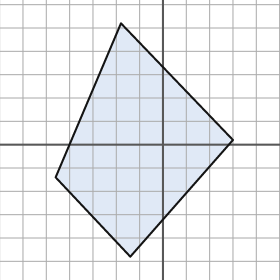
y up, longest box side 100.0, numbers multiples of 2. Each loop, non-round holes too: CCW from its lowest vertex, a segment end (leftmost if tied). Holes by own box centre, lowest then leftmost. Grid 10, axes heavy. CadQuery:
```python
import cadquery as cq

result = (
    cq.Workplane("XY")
    .moveTo(-14.0, -48.0)
    .lineTo(30.0, 2.0)
    .lineTo(-18.0, 52.0)
    .lineTo(-46.0, -14.0)
    .close()
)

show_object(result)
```